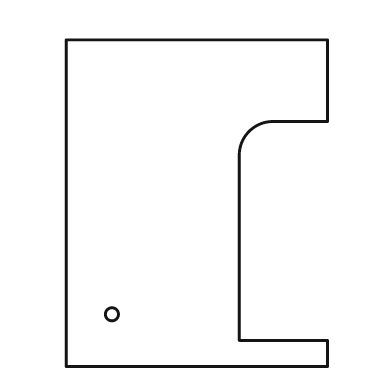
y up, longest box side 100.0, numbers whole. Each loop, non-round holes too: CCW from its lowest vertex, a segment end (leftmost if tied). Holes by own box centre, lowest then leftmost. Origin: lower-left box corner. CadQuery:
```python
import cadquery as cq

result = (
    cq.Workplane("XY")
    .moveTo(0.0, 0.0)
    .lineTo(80.0, 0.0)
    .lineTo(80.0, 8.0)
    .lineTo(53.0, 8.0)
    .lineTo(53.0, 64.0)
    .threePointArc((56.0, 72.0), (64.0, 75.0))
    .lineTo(80.0, 75.0)
    .lineTo(80.0, 100.0)
    .lineTo(0.0, 100.0)
    .close()
    .moveTo(14.0, 16.0)
    .circle(2.0)
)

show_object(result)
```